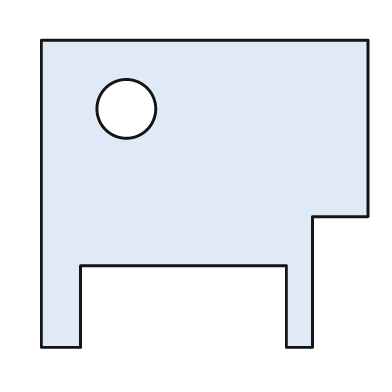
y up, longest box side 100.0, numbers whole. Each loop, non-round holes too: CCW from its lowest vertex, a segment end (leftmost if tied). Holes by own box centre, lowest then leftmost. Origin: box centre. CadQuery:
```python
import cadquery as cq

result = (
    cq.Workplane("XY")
    .moveTo(-50.0, -47.0)
    .lineTo(-38.0, -47.0)
    .lineTo(-38.0, -22.0)
    .lineTo(25.0, -22.0)
    .lineTo(25.0, -47.0)
    .lineTo(33.0, -47.0)
    .lineTo(33.0, -7.0)
    .lineTo(50.0, -7.0)
    .lineTo(50.0, 47.0)
    .lineTo(-50.0, 47.0)
    .close()
    .moveTo(-24.0, 26.0)
    .circle(9.0)
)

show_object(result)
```